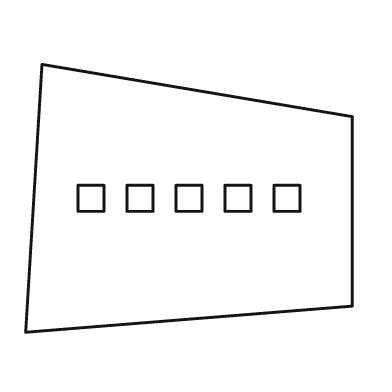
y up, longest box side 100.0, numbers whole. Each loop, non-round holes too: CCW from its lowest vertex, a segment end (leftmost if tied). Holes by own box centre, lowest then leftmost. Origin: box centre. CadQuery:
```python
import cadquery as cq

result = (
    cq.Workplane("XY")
    .moveTo(-50.0, -41.0)
    .lineTo(50.0, -33.0)
    .lineTo(50.0, 25.0)
    .lineTo(-45.0, 41.0)
    .close()
    .moveTo(-34.0, -4.0)
    .lineTo(-26.0, -4.0)
    .lineTo(-26.0, 4.0)
    .lineTo(-34.0, 4.0)
    .close()
    .moveTo(-19.0, -4.0)
    .lineTo(-11.0, -4.0)
    .lineTo(-11.0, 4.0)
    .lineTo(-19.0, 4.0)
    .close()
    .moveTo(-4.0, -4.0)
    .lineTo(4.0, -4.0)
    .lineTo(4.0, 4.0)
    .lineTo(-4.0, 4.0)
    .close()
    .moveTo(11.0, -4.0)
    .lineTo(19.0, -4.0)
    .lineTo(19.0, 4.0)
    .lineTo(11.0, 4.0)
    .close()
    .moveTo(26.0, -4.0)
    .lineTo(34.0, -4.0)
    .lineTo(34.0, 4.0)
    .lineTo(26.0, 4.0)
    .close()
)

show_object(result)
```